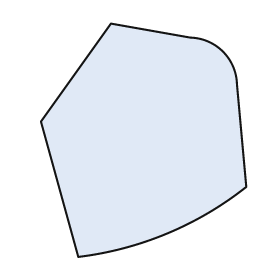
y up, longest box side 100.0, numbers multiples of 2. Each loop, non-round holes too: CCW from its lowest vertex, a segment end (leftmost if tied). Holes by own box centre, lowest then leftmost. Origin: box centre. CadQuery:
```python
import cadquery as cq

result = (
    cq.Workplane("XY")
    .moveTo(-28.0, -50.0)
    .threePointArc((10.0, -40.0), (44.0, -20.0))
    .lineTo(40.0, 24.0)
    .threePointArc((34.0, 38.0), (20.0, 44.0))
    .lineTo(-14.0, 50.0)
    .lineTo(-44.0, 8.0)
    .close()
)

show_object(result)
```